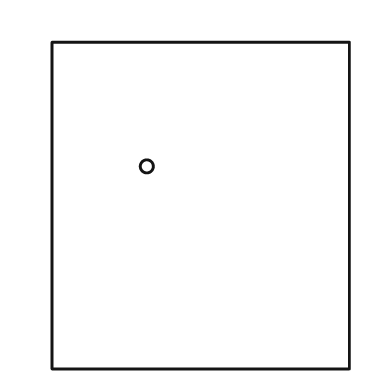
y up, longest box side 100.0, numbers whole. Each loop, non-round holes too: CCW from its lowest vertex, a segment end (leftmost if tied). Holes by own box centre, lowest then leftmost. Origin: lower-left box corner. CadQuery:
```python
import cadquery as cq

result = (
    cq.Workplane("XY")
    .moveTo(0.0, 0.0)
    .lineTo(91.0, 0.0)
    .lineTo(91.0, 100.0)
    .lineTo(0.0, 100.0)
    .close()
    .moveTo(29.0, 62.0)
    .circle(2.0)
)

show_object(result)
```